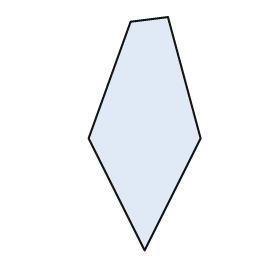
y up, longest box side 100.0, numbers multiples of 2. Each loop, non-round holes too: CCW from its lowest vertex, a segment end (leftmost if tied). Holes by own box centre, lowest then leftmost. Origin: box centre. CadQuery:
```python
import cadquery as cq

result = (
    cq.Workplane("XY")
    .moveTo(0.0, -50.0)
    .lineTo(24.0, -2.0)
    .lineTo(10.0, 50.0)
    .lineTo(-6.0, 48.0)
    .lineTo(-24.0, -2.0)
    .close()
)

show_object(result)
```